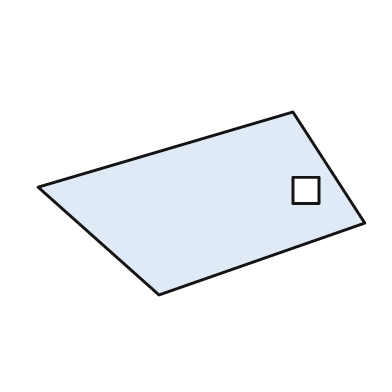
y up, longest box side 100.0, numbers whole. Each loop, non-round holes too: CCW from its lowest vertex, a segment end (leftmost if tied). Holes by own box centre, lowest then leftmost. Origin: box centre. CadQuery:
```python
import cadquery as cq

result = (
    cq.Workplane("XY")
    .moveTo(-13.0, -28.0)
    .lineTo(50.0, -6.0)
    .lineTo(28.0, 28.0)
    .lineTo(-50.0, 5.0)
    .close()
    .moveTo(28.0, 0.0)
    .lineTo(36.0, 0.0)
    .lineTo(36.0, 8.0)
    .lineTo(28.0, 8.0)
    .close()
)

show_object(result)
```